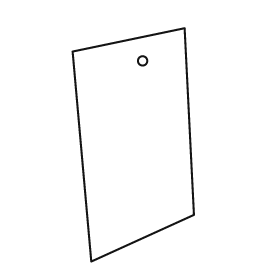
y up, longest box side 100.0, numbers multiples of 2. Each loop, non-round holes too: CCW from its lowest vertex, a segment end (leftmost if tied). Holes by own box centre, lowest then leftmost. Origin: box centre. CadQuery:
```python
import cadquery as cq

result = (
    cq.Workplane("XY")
    .moveTo(-18.0, -50.0)
    .lineTo(26.0, -30.0)
    .lineTo(22.0, 50.0)
    .lineTo(-26.0, 40.0)
    .close()
    .moveTo(4.0, 36.0)
    .circle(2.0)
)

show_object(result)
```